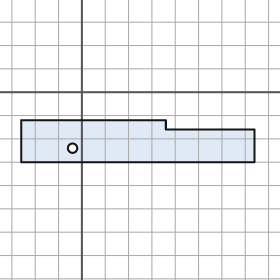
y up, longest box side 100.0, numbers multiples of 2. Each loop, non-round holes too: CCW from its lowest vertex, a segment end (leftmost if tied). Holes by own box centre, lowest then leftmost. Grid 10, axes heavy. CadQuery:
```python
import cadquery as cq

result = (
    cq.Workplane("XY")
    .moveTo(-26.0, -30.0)
    .lineTo(74.0, -30.0)
    .lineTo(74.0, -16.0)
    .lineTo(36.0, -16.0)
    .lineTo(36.0, -12.0)
    .lineTo(-26.0, -12.0)
    .close()
    .moveTo(-4.0, -24.0)
    .circle(2.0)
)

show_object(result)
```